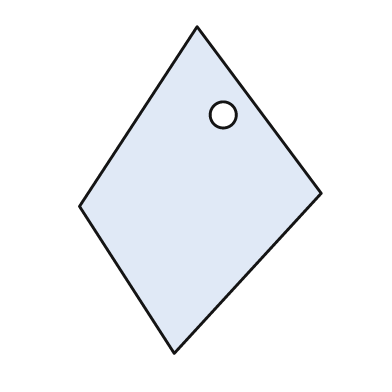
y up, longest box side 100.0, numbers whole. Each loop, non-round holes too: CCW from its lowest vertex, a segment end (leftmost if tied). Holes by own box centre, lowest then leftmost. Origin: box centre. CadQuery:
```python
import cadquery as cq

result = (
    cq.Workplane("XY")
    .moveTo(-8.0, -50.0)
    .lineTo(37.0, -1.0)
    .lineTo(-1.0, 50.0)
    .lineTo(-37.0, -5.0)
    .close()
    .moveTo(7.0, 23.0)
    .circle(4.0)
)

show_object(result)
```